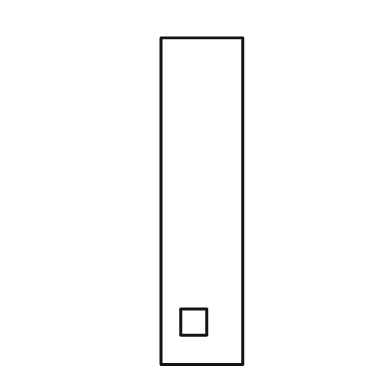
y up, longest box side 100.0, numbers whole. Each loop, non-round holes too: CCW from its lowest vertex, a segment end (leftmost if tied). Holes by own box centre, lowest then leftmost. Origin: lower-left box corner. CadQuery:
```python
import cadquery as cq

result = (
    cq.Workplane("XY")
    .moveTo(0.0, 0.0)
    .lineTo(25.0, 0.0)
    .lineTo(25.0, 100.0)
    .lineTo(0.0, 100.0)
    .close()
    .moveTo(6.0, 9.0)
    .lineTo(14.0, 9.0)
    .lineTo(14.0, 17.0)
    .lineTo(6.0, 17.0)
    .close()
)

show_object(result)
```